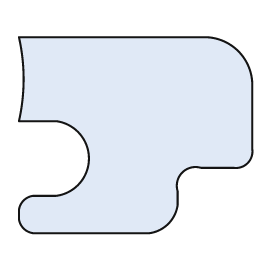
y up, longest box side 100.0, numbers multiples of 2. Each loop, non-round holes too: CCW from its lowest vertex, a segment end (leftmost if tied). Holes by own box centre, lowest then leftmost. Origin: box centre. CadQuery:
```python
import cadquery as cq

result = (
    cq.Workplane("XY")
    .moveTo(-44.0, -42.0)
    .lineTo(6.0, -42.0)
    .threePointArc((14.0, -38.0), (18.0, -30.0))
    .lineTo(18.0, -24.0)
    .threePointArc((20.0, -16.0), (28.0, -14.0))
    .lineTo(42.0, -14.0)
    .threePointArc((48.0, -12.0), (50.0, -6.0))
    .lineTo(50.0, 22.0)
    .threePointArc((44.0, 36.0), (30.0, 42.0))
    .lineTo(-50.0, 42.0)
    .threePointArc((-48.0, 24.0), (-50.0, 6.0))
    .lineTo(-34.0, 6.0)
    .threePointArc((-20.0, -10.0), (-34.0, -26.0))
    .lineTo(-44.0, -26.0)
    .threePointArc((-48.0, -28.0), (-50.0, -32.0))
    .lineTo(-50.0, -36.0)
    .threePointArc((-48.0, -40.0), (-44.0, -42.0))
    .close()
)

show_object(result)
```